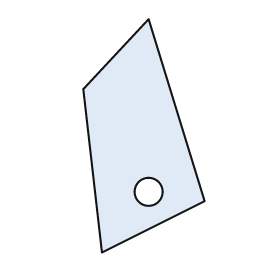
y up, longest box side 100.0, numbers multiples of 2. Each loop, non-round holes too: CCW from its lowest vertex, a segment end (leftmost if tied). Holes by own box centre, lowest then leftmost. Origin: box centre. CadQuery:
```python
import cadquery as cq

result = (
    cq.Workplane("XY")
    .moveTo(-18.0, -50.0)
    .lineTo(26.0, -28.0)
    .lineTo(2.0, 50.0)
    .lineTo(-26.0, 20.0)
    .close()
    .moveTo(2.0, -24.0)
    .circle(6.0)
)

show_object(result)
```